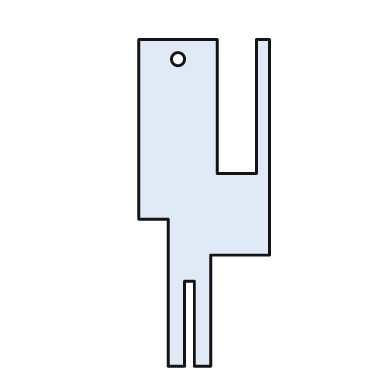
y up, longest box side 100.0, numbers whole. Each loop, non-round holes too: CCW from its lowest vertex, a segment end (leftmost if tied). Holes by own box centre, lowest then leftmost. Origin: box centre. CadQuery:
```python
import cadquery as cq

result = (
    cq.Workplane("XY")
    .moveTo(-11.0, -50.0)
    .lineTo(-6.0, -50.0)
    .lineTo(-6.0, -24.0)
    .lineTo(-3.0, -24.0)
    .lineTo(-3.0, -50.0)
    .lineTo(2.0, -50.0)
    .lineTo(2.0, -16.0)
    .lineTo(20.0, -16.0)
    .lineTo(20.0, 50.0)
    .lineTo(16.0, 50.0)
    .lineTo(16.0, 9.0)
    .lineTo(4.0, 9.0)
    .lineTo(4.0, 50.0)
    .lineTo(-20.0, 50.0)
    .lineTo(-20.0, -5.0)
    .lineTo(-11.0, -5.0)
    .close()
    .moveTo(-8.0, 44.0)
    .circle(2.0)
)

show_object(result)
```